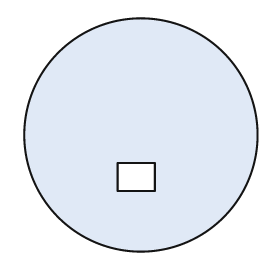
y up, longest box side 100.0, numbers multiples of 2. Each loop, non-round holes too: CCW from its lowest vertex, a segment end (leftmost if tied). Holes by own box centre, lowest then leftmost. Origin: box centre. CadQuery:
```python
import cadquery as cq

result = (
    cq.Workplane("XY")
    .moveTo(0.0, 0.0)
    .circle(50.0)
    .moveTo(-10.0, -24.0)
    .lineTo(6.0, -24.0)
    .lineTo(6.0, -12.0)
    .lineTo(-10.0, -12.0)
    .close()
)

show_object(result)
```